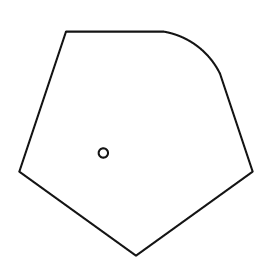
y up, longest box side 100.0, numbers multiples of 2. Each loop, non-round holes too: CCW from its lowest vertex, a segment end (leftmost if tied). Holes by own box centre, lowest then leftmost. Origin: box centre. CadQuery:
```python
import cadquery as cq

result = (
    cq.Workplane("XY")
    .moveTo(0.0, -48.0)
    .lineTo(50.0, -12.0)
    .lineTo(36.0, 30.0)
    .threePointArc((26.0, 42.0), (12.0, 48.0))
    .lineTo(-30.0, 48.0)
    .lineTo(-50.0, -12.0)
    .close()
    .moveTo(-14.0, -4.0)
    .circle(2.0)
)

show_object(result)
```